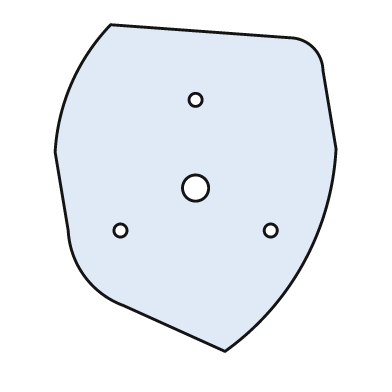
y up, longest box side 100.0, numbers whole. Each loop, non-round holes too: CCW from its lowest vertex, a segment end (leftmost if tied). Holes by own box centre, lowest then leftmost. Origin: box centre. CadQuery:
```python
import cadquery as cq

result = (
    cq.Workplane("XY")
    .moveTo(9.0, -50.0)
    .threePointArc((33.0, -23.0), (43.0, 12.0))
    .lineTo(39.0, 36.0)
    .threePointArc((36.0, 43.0), (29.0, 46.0))
    .lineTo(-26.0, 50.0)
    .threePointArc((-38.0, 32.0), (-43.0, 11.0))
    .lineTo(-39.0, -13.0)
    .threePointArc((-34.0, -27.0), (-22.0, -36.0))
    .close()
    .moveTo(-23.0, -13.0)
    .circle(2.0)
    .moveTo(23.0, -13.0)
    .circle(2.0)
    .moveTo(0.0, 0.0)
    .circle(4.0)
    .moveTo(0.0, 27.0)
    .circle(2.0)
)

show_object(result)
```